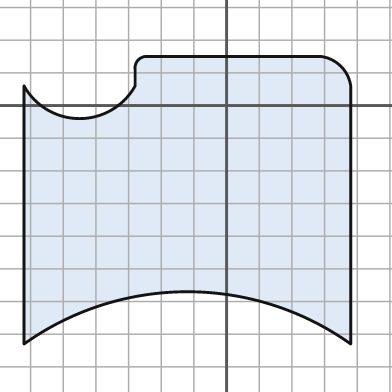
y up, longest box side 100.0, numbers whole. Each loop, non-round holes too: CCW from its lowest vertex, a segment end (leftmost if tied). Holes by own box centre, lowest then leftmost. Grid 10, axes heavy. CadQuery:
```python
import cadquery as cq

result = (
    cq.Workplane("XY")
    .moveTo(-62.0, -73.0)
    .threePointArc((-12.0, -57.0), (38.0, -73.0))
    .lineTo(38.0, 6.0)
    .threePointArc((35.0, 12.0), (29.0, 15.0))
    .lineTo(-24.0, 15.0)
    .threePointArc((-27.0, 14.0), (-28.0, 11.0))
    .lineTo(-28.0, 6.0)
    .threePointArc((-45.0, -4.0), (-62.0, 6.0))
    .close()
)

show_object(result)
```